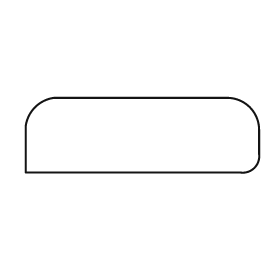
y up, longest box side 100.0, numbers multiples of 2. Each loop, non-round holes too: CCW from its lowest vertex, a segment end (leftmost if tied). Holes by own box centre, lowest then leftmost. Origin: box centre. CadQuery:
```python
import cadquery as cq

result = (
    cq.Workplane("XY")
    .moveTo(-50.0, -16.0)
    .lineTo(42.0, -16.0)
    .threePointArc((48.0, -14.0), (50.0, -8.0))
    .lineTo(50.0, 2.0)
    .threePointArc((46.0, 12.0), (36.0, 16.0))
    .lineTo(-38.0, 16.0)
    .threePointArc((-46.0, 12.0), (-50.0, 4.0))
    .close()
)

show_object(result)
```